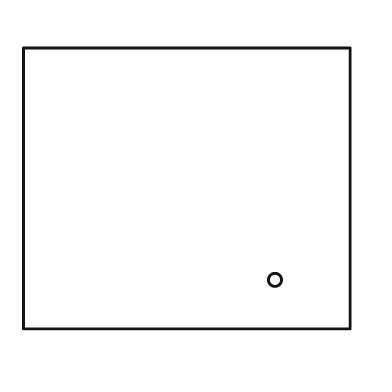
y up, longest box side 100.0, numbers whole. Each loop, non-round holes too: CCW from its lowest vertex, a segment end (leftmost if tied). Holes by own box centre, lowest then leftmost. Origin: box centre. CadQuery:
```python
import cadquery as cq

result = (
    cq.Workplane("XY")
    .moveTo(-50.0, -43.0)
    .lineTo(50.0, -43.0)
    .lineTo(50.0, 43.0)
    .lineTo(-50.0, 43.0)
    .close()
    .moveTo(27.0, -28.0)
    .circle(2.0)
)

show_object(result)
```